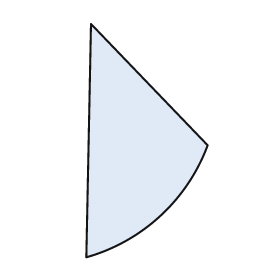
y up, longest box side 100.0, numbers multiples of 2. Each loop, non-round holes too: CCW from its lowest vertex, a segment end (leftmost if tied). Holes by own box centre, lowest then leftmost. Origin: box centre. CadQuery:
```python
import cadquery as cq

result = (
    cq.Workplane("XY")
    .moveTo(-26.0, -50.0)
    .threePointArc((6.0, -32.0), (26.0, -2.0))
    .lineTo(-24.0, 50.0)
    .close()
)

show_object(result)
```